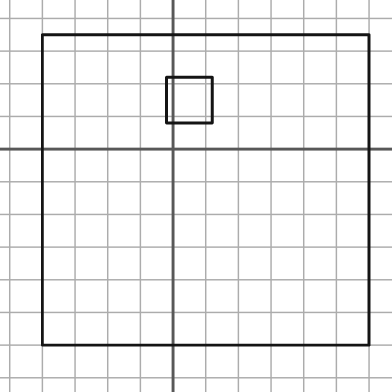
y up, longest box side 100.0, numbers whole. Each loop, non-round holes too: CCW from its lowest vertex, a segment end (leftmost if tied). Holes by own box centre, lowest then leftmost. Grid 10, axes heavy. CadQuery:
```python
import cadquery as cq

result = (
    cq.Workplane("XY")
    .moveTo(-40.0, -60.0)
    .lineTo(60.0, -60.0)
    .lineTo(60.0, 35.0)
    .lineTo(-40.0, 35.0)
    .close()
    .moveTo(-2.0, 8.0)
    .lineTo(12.0, 8.0)
    .lineTo(12.0, 22.0)
    .lineTo(-2.0, 22.0)
    .close()
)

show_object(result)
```